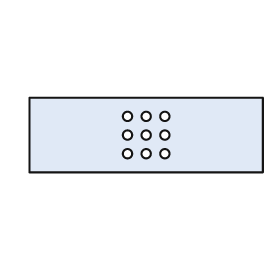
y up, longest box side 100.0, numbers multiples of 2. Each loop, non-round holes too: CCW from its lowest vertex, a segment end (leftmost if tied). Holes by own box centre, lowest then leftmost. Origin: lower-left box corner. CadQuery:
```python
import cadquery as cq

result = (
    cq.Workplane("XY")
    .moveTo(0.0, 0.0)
    .lineTo(100.0, 0.0)
    .lineTo(100.0, 32.0)
    .lineTo(0.0, 32.0)
    .close()
    .moveTo(42.0, 8.0)
    .circle(2.0)
    .moveTo(50.0, 8.0)
    .circle(2.0)
    .moveTo(58.0, 8.0)
    .circle(2.0)
    .moveTo(42.0, 16.0)
    .circle(2.0)
    .moveTo(50.0, 16.0)
    .circle(2.0)
    .moveTo(58.0, 16.0)
    .circle(2.0)
    .moveTo(42.0, 24.0)
    .circle(2.0)
    .moveTo(50.0, 24.0)
    .circle(2.0)
    .moveTo(58.0, 24.0)
    .circle(2.0)
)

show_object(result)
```